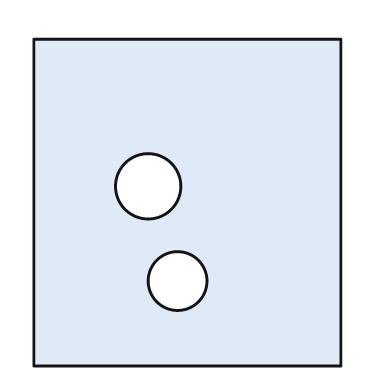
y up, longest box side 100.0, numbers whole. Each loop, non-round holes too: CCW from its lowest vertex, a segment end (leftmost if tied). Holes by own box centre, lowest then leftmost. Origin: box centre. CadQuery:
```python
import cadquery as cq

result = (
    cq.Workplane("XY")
    .moveTo(-47.0, -50.0)
    .lineTo(47.0, -50.0)
    .lineTo(47.0, 50.0)
    .lineTo(-47.0, 50.0)
    .close()
    .moveTo(-3.0, -24.0)
    .circle(9.0)
    .moveTo(-12.0, 5.0)
    .circle(10.0)
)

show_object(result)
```